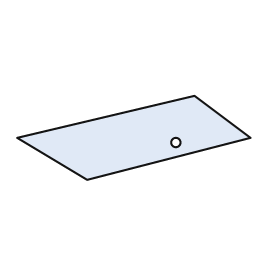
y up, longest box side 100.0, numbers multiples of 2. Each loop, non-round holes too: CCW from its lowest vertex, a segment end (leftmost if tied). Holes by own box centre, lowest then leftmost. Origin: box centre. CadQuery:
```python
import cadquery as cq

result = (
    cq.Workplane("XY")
    .moveTo(-20.0, -18.0)
    .lineTo(50.0, 0.0)
    .lineTo(26.0, 18.0)
    .lineTo(-50.0, 0.0)
    .close()
    .moveTo(18.0, -2.0)
    .circle(2.0)
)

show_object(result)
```